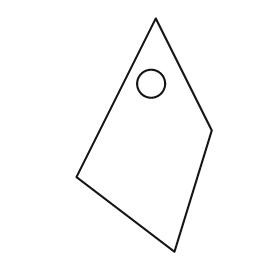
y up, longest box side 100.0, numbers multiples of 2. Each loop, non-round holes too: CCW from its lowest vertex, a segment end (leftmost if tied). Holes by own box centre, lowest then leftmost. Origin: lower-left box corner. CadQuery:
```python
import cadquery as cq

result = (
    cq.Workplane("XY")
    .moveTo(42.0, 0.0)
    .lineTo(58.0, 52.0)
    .lineTo(34.0, 100.0)
    .lineTo(0.0, 32.0)
    .close()
    .moveTo(32.0, 72.0)
    .circle(6.0)
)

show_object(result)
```